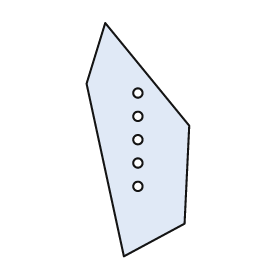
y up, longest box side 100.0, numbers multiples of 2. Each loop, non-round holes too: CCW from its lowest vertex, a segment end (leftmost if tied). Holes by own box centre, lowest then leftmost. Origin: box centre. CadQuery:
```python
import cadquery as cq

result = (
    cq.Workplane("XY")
    .moveTo(-6.0, -50.0)
    .lineTo(20.0, -36.0)
    .lineTo(22.0, 6.0)
    .lineTo(-14.0, 50.0)
    .lineTo(-22.0, 24.0)
    .close()
    .moveTo(0.0, -20.0)
    .circle(2.0)
    .moveTo(0.0, -10.0)
    .circle(2.0)
    .moveTo(0.0, 0.0)
    .circle(2.0)
    .moveTo(0.0, 10.0)
    .circle(2.0)
    .moveTo(0.0, 20.0)
    .circle(2.0)
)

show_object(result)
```